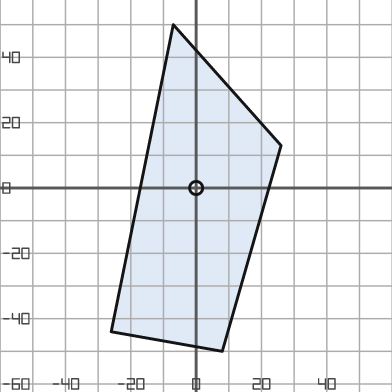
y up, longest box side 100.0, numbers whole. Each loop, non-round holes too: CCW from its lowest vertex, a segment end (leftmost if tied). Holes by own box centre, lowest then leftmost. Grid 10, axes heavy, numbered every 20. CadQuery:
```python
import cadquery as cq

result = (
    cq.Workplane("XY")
    .moveTo(8.0, -50.0)
    .lineTo(26.0, 13.0)
    .lineTo(-7.0, 50.0)
    .lineTo(-26.0, -44.0)
    .close()
    .moveTo(0.0, 0.0)
    .circle(2.0)
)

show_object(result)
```